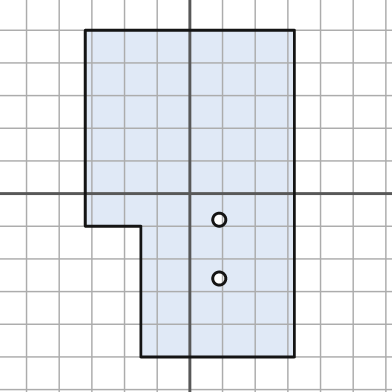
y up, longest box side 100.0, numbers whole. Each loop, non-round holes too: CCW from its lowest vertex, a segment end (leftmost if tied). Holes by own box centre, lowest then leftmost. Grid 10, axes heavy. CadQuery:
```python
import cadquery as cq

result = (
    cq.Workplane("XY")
    .moveTo(-15.0, -50.0)
    .lineTo(32.0, -50.0)
    .lineTo(32.0, 50.0)
    .lineTo(-32.0, 50.0)
    .lineTo(-32.0, -10.0)
    .lineTo(-15.0, -10.0)
    .close()
    .moveTo(9.0, -26.0)
    .circle(2.0)
    .moveTo(9.0, -8.0)
    .circle(2.0)
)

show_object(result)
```